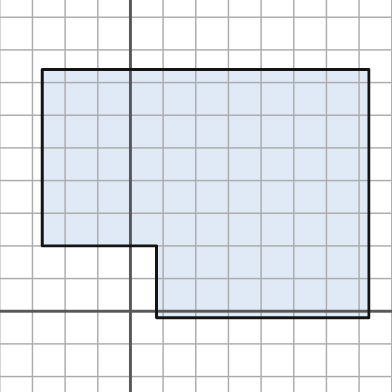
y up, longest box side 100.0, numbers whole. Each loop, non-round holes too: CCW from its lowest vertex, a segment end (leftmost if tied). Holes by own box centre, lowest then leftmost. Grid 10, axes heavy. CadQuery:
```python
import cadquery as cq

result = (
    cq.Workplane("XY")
    .moveTo(8.0, -2.0)
    .lineTo(73.0, -2.0)
    .lineTo(73.0, 74.0)
    .lineTo(-27.0, 74.0)
    .lineTo(-27.0, 20.0)
    .lineTo(8.0, 20.0)
    .close()
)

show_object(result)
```